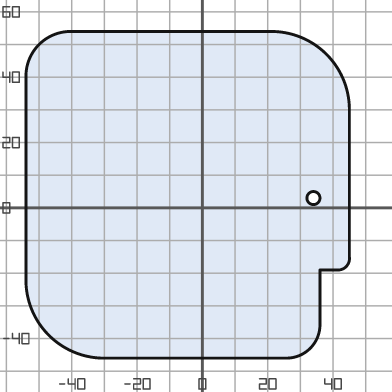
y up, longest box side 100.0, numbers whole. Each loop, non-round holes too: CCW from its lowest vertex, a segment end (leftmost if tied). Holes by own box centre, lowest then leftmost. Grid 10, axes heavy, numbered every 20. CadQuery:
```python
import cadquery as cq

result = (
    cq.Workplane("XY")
    .moveTo(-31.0, -46.0)
    .lineTo(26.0, -46.0)
    .threePointArc((33.0, -43.0), (36.0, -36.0))
    .lineTo(36.0, -19.0)
    .lineTo(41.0, -19.0)
    .threePointArc((44.0, -18.0), (45.0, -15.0))
    .lineTo(45.0, 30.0)
    .threePointArc((38.0, 47.0), (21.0, 54.0))
    .lineTo(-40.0, 54.0)
    .threePointArc((-50.0, 50.0), (-54.0, 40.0))
    .lineTo(-54.0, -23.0)
    .threePointArc((-47.0, -39.0), (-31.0, -46.0))
    .close()
    .moveTo(34.0, 3.0)
    .circle(2.0)
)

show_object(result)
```